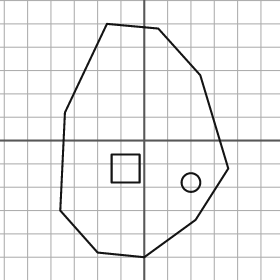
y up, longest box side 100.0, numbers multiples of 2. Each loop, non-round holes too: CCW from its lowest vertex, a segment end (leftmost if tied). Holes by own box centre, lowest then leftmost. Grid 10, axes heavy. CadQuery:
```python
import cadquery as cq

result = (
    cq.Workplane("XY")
    .moveTo(0.0, -50.0)
    .lineTo(22.0, -34.0)
    .lineTo(36.0, -12.0)
    .lineTo(24.0, 28.0)
    .lineTo(6.0, 48.0)
    .lineTo(-16.0, 50.0)
    .lineTo(-34.0, 12.0)
    .lineTo(-36.0, -30.0)
    .lineTo(-20.0, -48.0)
    .close()
    .moveTo(20.0, -18.0)
    .circle(4.0)
    .moveTo(-14.0, -18.0)
    .lineTo(-2.0, -18.0)
    .lineTo(-2.0, -6.0)
    .lineTo(-14.0, -6.0)
    .close()
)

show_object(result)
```